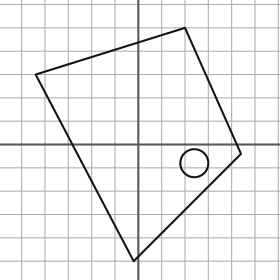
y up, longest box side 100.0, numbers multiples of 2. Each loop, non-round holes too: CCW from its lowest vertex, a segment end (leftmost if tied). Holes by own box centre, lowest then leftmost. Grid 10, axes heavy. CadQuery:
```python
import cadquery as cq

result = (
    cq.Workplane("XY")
    .moveTo(-2.0, -50.0)
    .lineTo(44.0, -4.0)
    .lineTo(20.0, 50.0)
    .lineTo(-44.0, 30.0)
    .close()
    .moveTo(24.0, -8.0)
    .circle(6.0)
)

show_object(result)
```